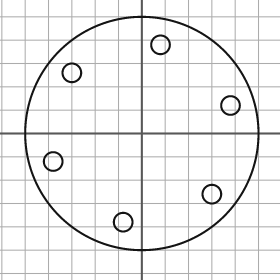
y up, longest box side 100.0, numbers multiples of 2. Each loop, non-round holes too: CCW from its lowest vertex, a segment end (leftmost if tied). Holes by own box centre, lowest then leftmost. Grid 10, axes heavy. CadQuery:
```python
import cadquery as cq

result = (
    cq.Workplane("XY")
    .moveTo(0.0, 0.0)
    .circle(50.0)
    .moveTo(-8.0, -38.0)
    .circle(4.0)
    .moveTo(30.0, -26.0)
    .circle(4.0)
    .moveTo(-38.0, -12.0)
    .circle(4.0)
    .moveTo(38.0, 12.0)
    .circle(4.0)
    .moveTo(-30.0, 26.0)
    .circle(4.0)
    .moveTo(8.0, 38.0)
    .circle(4.0)
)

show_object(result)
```